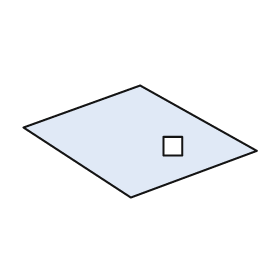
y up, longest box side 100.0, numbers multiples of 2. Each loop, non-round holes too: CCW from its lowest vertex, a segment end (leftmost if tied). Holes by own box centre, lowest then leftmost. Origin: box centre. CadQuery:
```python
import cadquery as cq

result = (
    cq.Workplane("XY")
    .moveTo(-4.0, -24.0)
    .lineTo(50.0, -4.0)
    .lineTo(0.0, 24.0)
    .lineTo(-50.0, 6.0)
    .close()
    .moveTo(10.0, -6.0)
    .lineTo(18.0, -6.0)
    .lineTo(18.0, 2.0)
    .lineTo(10.0, 2.0)
    .close()
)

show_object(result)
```